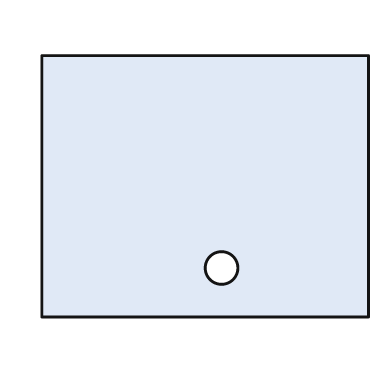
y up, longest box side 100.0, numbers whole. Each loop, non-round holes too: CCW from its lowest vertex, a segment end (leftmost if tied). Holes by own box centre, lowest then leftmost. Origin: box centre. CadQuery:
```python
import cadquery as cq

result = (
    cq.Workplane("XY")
    .moveTo(-50.0, -40.0)
    .lineTo(50.0, -40.0)
    .lineTo(50.0, 40.0)
    .lineTo(-50.0, 40.0)
    .close()
    .moveTo(5.0, -25.0)
    .circle(5.0)
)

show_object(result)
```